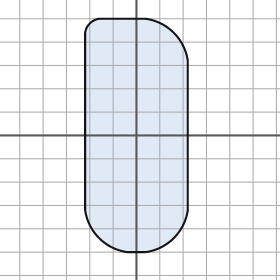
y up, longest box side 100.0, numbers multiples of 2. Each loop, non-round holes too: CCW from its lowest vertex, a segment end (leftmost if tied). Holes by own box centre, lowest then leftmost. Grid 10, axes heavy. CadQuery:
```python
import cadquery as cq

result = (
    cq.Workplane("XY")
    .moveTo(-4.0, -50.0)
    .lineTo(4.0, -50.0)
    .threePointArc((16.0, -44.0), (22.0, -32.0))
    .lineTo(22.0, 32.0)
    .threePointArc((16.0, 44.0), (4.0, 50.0))
    .lineTo(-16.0, 50.0)
    .threePointArc((-20.0, 48.0), (-22.0, 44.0))
    .lineTo(-22.0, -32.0)
    .threePointArc((-16.0, -44.0), (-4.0, -50.0))
    .close()
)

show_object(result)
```